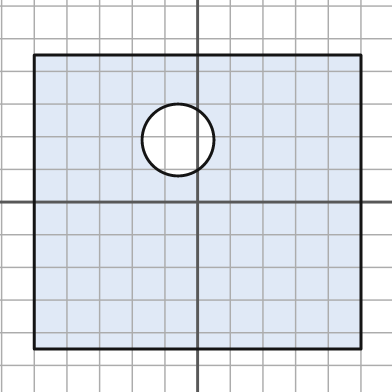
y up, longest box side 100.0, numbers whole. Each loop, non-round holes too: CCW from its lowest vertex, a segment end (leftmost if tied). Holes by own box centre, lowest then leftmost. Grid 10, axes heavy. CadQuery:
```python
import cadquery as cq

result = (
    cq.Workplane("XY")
    .moveTo(-50.0, -45.0)
    .lineTo(50.0, -45.0)
    .lineTo(50.0, 45.0)
    .lineTo(-50.0, 45.0)
    .close()
    .moveTo(-6.0, 19.0)
    .circle(11.0)
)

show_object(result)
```